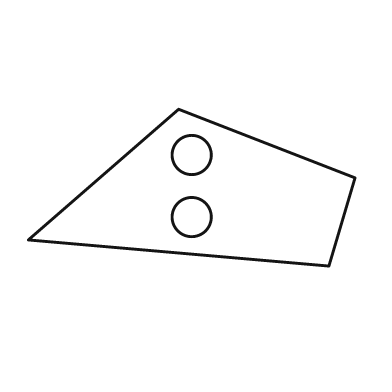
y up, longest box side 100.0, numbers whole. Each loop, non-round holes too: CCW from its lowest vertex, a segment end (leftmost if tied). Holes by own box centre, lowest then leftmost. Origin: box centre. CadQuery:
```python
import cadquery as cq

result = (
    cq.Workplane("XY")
    .moveTo(42.0, -24.0)
    .lineTo(50.0, 3.0)
    .lineTo(-4.0, 24.0)
    .lineTo(-50.0, -16.0)
    .close()
    .moveTo(0.0, -9.0)
    .circle(6.0)
    .moveTo(0.0, 10.0)
    .circle(6.0)
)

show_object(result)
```